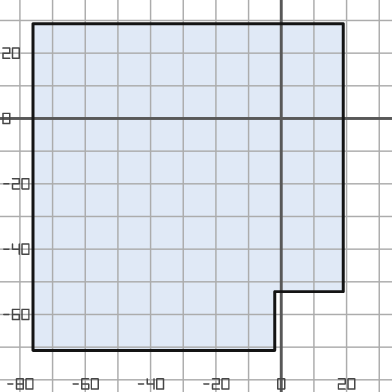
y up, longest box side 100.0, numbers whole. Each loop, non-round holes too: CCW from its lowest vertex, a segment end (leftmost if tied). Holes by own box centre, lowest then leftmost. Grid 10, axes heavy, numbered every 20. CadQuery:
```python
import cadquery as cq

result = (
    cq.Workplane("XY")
    .moveTo(-76.0, -71.0)
    .lineTo(-2.0, -71.0)
    .lineTo(-2.0, -53.0)
    .lineTo(19.0, -53.0)
    .lineTo(19.0, 29.0)
    .lineTo(-76.0, 29.0)
    .close()
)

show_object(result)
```